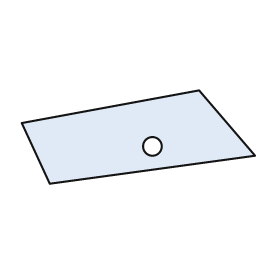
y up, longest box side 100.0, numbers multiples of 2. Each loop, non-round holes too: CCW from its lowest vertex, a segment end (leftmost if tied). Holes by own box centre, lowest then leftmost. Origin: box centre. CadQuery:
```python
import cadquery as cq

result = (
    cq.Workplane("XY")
    .moveTo(-38.0, -20.0)
    .lineTo(50.0, -8.0)
    .lineTo(26.0, 20.0)
    .lineTo(-50.0, 6.0)
    .close()
    .moveTo(6.0, -4.0)
    .circle(4.0)
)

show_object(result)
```